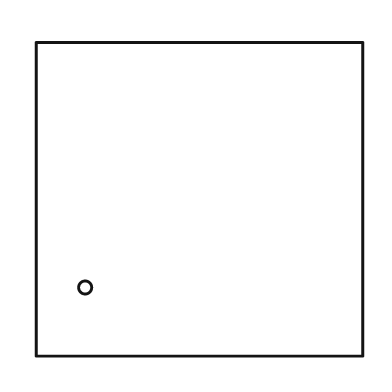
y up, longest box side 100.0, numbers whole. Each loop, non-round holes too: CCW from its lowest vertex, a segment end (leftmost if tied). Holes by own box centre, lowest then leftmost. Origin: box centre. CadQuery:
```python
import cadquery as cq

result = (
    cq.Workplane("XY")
    .moveTo(-50.0, -48.0)
    .lineTo(50.0, -48.0)
    .lineTo(50.0, 48.0)
    .lineTo(-50.0, 48.0)
    .close()
    .moveTo(-35.0, -27.0)
    .circle(2.0)
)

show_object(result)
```